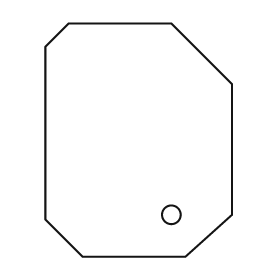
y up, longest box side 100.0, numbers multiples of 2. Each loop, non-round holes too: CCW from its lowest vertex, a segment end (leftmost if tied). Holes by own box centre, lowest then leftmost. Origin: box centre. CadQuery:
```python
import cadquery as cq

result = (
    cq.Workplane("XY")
    .moveTo(-24.0, -50.0)
    .lineTo(20.0, -50.0)
    .lineTo(40.0, -32.0)
    .lineTo(40.0, 24.0)
    .lineTo(14.0, 50.0)
    .lineTo(-30.0, 50.0)
    .lineTo(-40.0, 40.0)
    .lineTo(-40.0, -34.0)
    .close()
    .moveTo(14.0, -32.0)
    .circle(4.0)
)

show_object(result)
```